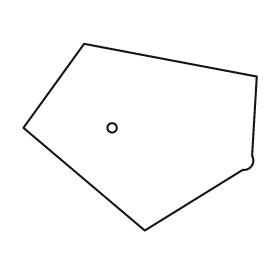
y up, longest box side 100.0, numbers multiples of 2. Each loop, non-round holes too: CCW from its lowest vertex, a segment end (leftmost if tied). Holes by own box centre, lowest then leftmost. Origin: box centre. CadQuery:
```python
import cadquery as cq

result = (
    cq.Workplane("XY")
    .moveTo(2.0, -40.0)
    .lineTo(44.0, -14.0)
    .threePointArc((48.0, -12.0), (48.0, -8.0))
    .lineTo(50.0, 26.0)
    .lineTo(-24.0, 40.0)
    .lineTo(-50.0, 4.0)
    .close()
    .moveTo(-12.0, 4.0)
    .circle(2.0)
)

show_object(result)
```